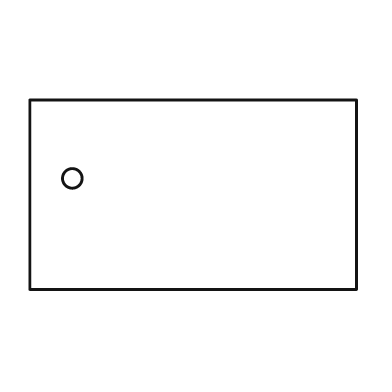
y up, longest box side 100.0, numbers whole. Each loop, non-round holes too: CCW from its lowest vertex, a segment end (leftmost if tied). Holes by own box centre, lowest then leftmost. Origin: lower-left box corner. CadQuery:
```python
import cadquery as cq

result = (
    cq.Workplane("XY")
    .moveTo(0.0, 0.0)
    .lineTo(100.0, 0.0)
    .lineTo(100.0, 58.0)
    .lineTo(0.0, 58.0)
    .close()
    .moveTo(13.0, 34.0)
    .circle(3.0)
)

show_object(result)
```